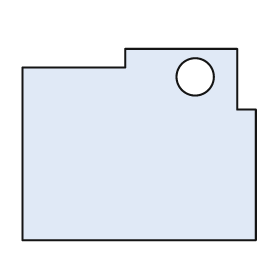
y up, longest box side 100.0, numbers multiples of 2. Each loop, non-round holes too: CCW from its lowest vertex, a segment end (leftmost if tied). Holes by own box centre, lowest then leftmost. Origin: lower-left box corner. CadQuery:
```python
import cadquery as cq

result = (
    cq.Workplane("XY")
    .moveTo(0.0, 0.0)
    .lineTo(100.0, 0.0)
    .lineTo(100.0, 56.0)
    .lineTo(92.0, 56.0)
    .lineTo(92.0, 82.0)
    .lineTo(44.0, 82.0)
    .lineTo(44.0, 74.0)
    .lineTo(0.0, 74.0)
    .close()
    .moveTo(74.0, 70.0)
    .circle(8.0)
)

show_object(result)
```